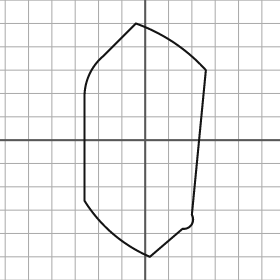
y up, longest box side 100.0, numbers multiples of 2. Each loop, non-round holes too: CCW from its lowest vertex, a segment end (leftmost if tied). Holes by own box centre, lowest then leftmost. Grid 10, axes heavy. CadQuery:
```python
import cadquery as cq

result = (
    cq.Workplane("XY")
    .moveTo(2.0, -50.0)
    .lineTo(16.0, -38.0)
    .threePointArc((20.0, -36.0), (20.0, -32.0))
    .lineTo(26.0, 30.0)
    .threePointArc((12.0, 42.0), (-4.0, 50.0))
    .lineTo(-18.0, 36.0)
    .threePointArc((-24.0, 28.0), (-26.0, 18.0))
    .lineTo(-26.0, -26.0)
    .threePointArc((-14.0, -40.0), (2.0, -50.0))
    .close()
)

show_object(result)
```